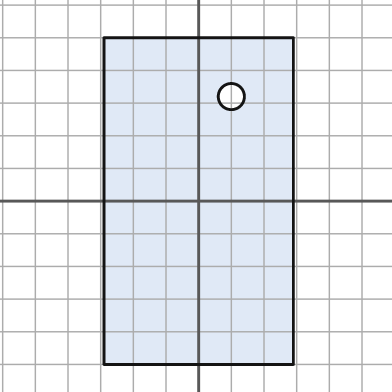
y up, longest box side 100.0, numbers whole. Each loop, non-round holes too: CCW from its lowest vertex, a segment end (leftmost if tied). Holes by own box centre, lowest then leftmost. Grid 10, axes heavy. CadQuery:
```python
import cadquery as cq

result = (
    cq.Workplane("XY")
    .moveTo(-29.0, -50.0)
    .lineTo(29.0, -50.0)
    .lineTo(29.0, 50.0)
    .lineTo(-29.0, 50.0)
    .close()
    .moveTo(10.0, 32.0)
    .circle(4.0)
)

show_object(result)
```